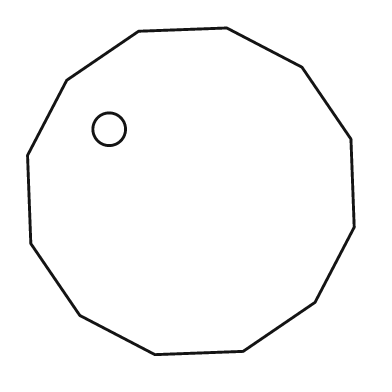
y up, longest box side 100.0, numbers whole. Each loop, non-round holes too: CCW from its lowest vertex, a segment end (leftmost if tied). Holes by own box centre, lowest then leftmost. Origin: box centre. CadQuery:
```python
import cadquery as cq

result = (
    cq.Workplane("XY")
    .moveTo(-11.0, -50.0)
    .lineTo(16.0, -49.0)
    .lineTo(38.0, -34.0)
    .lineTo(50.0, -11.0)
    .lineTo(49.0, 16.0)
    .lineTo(34.0, 38.0)
    .lineTo(11.0, 50.0)
    .lineTo(-16.0, 49.0)
    .lineTo(-38.0, 34.0)
    .lineTo(-50.0, 11.0)
    .lineTo(-49.0, -16.0)
    .lineTo(-34.0, -38.0)
    .close()
    .moveTo(-25.0, 19.0)
    .circle(5.0)
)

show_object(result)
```